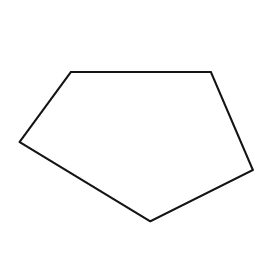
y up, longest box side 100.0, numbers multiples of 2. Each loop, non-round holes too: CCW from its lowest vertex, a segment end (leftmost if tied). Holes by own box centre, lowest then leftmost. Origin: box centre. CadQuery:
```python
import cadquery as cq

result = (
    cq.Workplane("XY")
    .moveTo(6.0, -32.0)
    .lineTo(50.0, -10.0)
    .lineTo(32.0, 32.0)
    .lineTo(-28.0, 32.0)
    .lineTo(-50.0, 2.0)
    .close()
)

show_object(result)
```